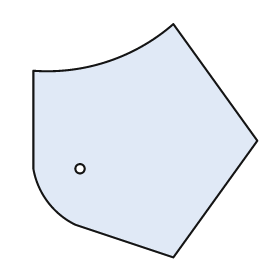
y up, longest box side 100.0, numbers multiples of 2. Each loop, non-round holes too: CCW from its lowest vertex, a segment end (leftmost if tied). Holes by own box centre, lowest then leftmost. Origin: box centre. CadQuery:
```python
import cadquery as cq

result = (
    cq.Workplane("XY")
    .moveTo(12.0, -50.0)
    .lineTo(48.0, 0.0)
    .lineTo(12.0, 50.0)
    .threePointArc((-16.0, 34.0), (-48.0, 30.0))
    .lineTo(-48.0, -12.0)
    .threePointArc((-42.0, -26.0), (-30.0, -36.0))
    .close()
    .moveTo(-28.0, -12.0)
    .circle(2.0)
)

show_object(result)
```